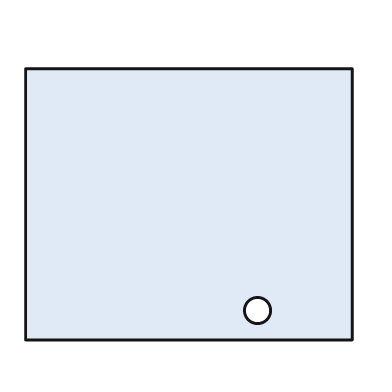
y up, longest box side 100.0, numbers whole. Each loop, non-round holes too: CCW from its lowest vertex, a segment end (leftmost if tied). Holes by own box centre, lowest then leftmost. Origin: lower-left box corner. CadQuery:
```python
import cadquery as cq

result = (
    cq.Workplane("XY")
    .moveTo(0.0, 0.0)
    .lineTo(100.0, 0.0)
    .lineTo(100.0, 83.0)
    .lineTo(0.0, 83.0)
    .close()
    .moveTo(71.0, 9.0)
    .circle(4.0)
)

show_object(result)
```